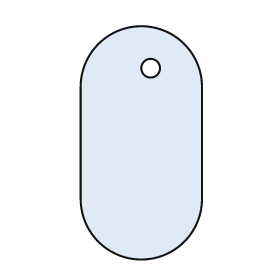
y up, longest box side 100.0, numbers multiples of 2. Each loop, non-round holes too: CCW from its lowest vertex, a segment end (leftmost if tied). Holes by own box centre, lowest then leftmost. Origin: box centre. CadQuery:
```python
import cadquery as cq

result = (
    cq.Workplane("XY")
    .moveTo(-26.0, -24.0)
    .threePointArc((0.0, -50.0), (26.0, -24.0))
    .lineTo(26.0, 24.0)
    .threePointArc((0.0, 50.0), (-26.0, 24.0))
    .close()
    .moveTo(4.0, 32.0)
    .circle(4.0)
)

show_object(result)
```